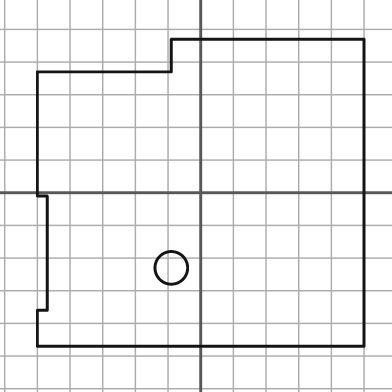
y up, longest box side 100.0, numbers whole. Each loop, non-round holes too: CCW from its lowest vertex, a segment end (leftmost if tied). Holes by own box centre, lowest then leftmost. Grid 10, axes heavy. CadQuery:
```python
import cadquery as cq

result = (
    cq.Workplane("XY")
    .moveTo(-50.0, -47.0)
    .lineTo(50.0, -47.0)
    .lineTo(50.0, 47.0)
    .lineTo(-9.0, 47.0)
    .lineTo(-9.0, 37.0)
    .lineTo(-50.0, 37.0)
    .lineTo(-50.0, -1.0)
    .lineTo(-47.0, -1.0)
    .lineTo(-47.0, -36.0)
    .lineTo(-50.0, -36.0)
    .close()
    .moveTo(-9.0, -23.0)
    .circle(5.0)
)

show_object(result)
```